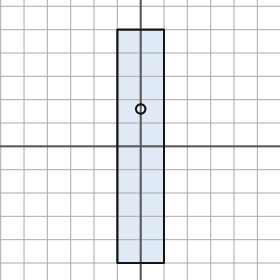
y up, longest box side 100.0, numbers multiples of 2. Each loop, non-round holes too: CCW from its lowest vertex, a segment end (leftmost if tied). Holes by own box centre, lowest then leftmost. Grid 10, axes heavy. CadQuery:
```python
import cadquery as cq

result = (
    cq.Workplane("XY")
    .moveTo(-10.0, -50.0)
    .lineTo(10.0, -50.0)
    .lineTo(10.0, 50.0)
    .lineTo(-10.0, 50.0)
    .close()
    .moveTo(0.0, 16.0)
    .circle(2.0)
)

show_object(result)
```